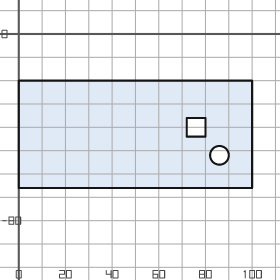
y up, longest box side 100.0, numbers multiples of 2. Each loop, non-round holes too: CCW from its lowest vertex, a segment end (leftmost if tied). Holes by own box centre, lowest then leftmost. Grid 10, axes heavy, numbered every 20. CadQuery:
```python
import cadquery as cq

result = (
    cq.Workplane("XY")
    .moveTo(0.0, -66.0)
    .lineTo(100.0, -66.0)
    .lineTo(100.0, -20.0)
    .lineTo(0.0, -20.0)
    .close()
    .moveTo(86.0, -52.0)
    .circle(4.0)
    .moveTo(72.0, -44.0)
    .lineTo(80.0, -44.0)
    .lineTo(80.0, -36.0)
    .lineTo(72.0, -36.0)
    .close()
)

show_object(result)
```